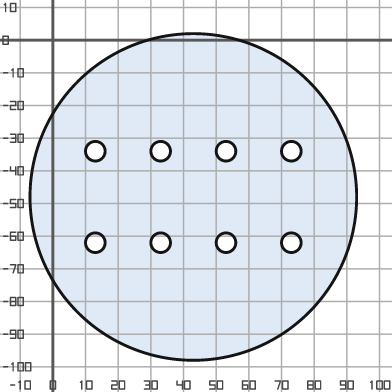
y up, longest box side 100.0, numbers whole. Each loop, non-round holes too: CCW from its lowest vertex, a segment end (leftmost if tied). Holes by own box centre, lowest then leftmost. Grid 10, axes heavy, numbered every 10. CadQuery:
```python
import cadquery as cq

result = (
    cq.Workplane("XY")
    .moveTo(43.0, -48.0)
    .circle(50.0)
    .moveTo(13.0, -62.0)
    .circle(3.0)
    .moveTo(33.0, -62.0)
    .circle(3.0)
    .moveTo(53.0, -62.0)
    .circle(3.0)
    .moveTo(73.0, -62.0)
    .circle(3.0)
    .moveTo(13.0, -34.0)
    .circle(3.0)
    .moveTo(33.0, -34.0)
    .circle(3.0)
    .moveTo(53.0, -34.0)
    .circle(3.0)
    .moveTo(73.0, -34.0)
    .circle(3.0)
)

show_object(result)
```